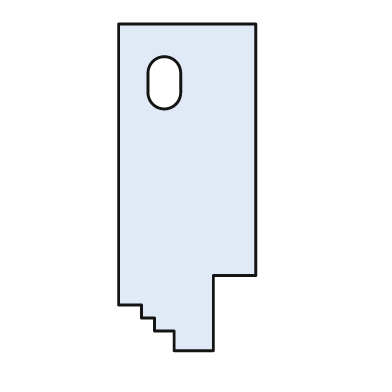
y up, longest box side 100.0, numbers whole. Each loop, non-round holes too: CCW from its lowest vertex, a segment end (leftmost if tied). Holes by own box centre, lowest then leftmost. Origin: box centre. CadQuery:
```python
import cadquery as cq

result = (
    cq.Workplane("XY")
    .moveTo(-4.0, -50.0)
    .lineTo(8.0, -50.0)
    .lineTo(8.0, -27.0)
    .lineTo(21.0, -27.0)
    .lineTo(21.0, 50.0)
    .lineTo(-21.0, 50.0)
    .lineTo(-21.0, -36.0)
    .lineTo(-14.0, -36.0)
    .lineTo(-14.0, -40.0)
    .lineTo(-10.0, -40.0)
    .lineTo(-10.0, -44.0)
    .lineTo(-4.0, -44.0)
    .close()
    .moveTo(-12.0, 29.0)
    .threePointArc((-7.0, 24.0), (-2.0, 29.0))
    .lineTo(-2.0, 35.0)
    .threePointArc((-7.0, 40.0), (-12.0, 35.0))
    .close()
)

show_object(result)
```